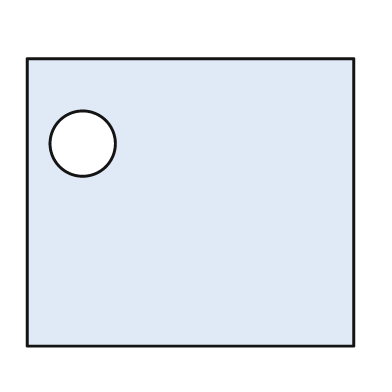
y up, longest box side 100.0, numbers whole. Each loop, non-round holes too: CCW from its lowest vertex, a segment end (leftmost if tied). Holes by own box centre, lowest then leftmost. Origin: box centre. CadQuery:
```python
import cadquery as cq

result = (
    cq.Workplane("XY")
    .moveTo(-50.0, -44.0)
    .lineTo(50.0, -44.0)
    .lineTo(50.0, 44.0)
    .lineTo(-50.0, 44.0)
    .close()
    .moveTo(-33.0, 18.0)
    .circle(10.0)
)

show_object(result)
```